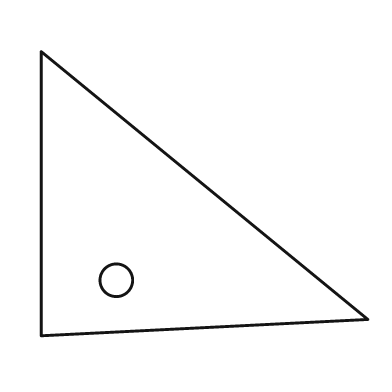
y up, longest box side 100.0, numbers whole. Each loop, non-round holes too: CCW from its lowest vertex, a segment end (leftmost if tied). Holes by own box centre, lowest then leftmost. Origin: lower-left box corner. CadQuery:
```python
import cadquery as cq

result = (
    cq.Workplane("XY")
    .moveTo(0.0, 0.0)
    .lineTo(100.0, 5.0)
    .lineTo(0.0, 87.0)
    .close()
    .moveTo(23.0, 17.0)
    .circle(5.0)
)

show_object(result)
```